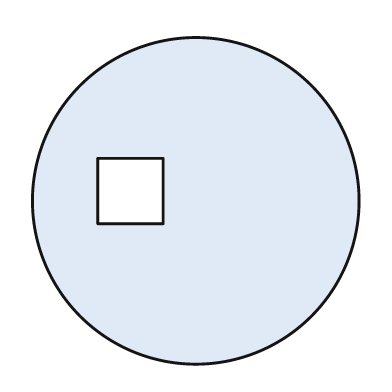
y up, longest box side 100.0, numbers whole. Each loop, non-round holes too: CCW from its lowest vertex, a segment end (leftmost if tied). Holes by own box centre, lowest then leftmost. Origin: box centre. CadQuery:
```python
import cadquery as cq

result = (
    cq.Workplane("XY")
    .moveTo(0.0, 0.0)
    .circle(50.0)
    .moveTo(-30.0, -7.0)
    .lineTo(-10.0, -7.0)
    .lineTo(-10.0, 13.0)
    .lineTo(-30.0, 13.0)
    .close()
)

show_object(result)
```